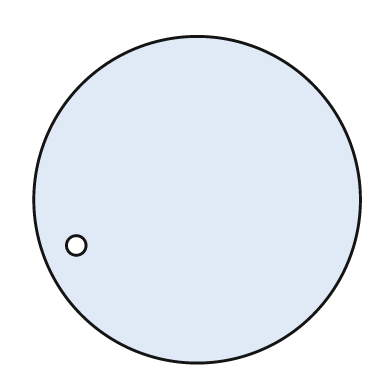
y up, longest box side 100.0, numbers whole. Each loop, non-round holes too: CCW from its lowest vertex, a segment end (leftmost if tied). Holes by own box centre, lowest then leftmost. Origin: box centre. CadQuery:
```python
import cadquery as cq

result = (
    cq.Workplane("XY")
    .moveTo(0.0, 0.0)
    .circle(50.0)
    .moveTo(-37.0, -14.0)
    .circle(3.0)
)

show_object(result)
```